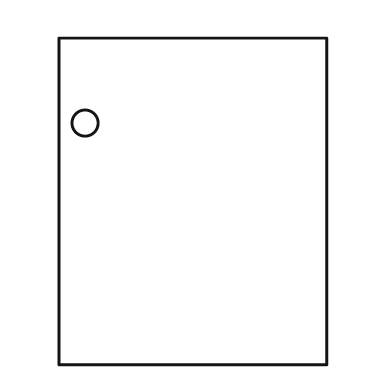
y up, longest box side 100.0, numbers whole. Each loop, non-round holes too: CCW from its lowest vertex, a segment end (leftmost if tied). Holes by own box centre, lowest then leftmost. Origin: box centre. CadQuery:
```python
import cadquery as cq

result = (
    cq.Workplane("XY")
    .moveTo(-41.0, -50.0)
    .lineTo(41.0, -50.0)
    .lineTo(41.0, 50.0)
    .lineTo(-41.0, 50.0)
    .close()
    .moveTo(-33.0, 24.0)
    .circle(4.0)
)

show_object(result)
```